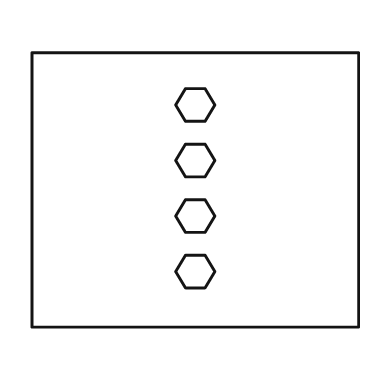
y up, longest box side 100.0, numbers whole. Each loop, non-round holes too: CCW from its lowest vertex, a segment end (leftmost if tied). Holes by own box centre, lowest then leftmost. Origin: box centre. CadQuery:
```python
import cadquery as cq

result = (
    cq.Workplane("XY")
    .moveTo(-50.0, -42.0)
    .lineTo(50.0, -42.0)
    .lineTo(50.0, 42.0)
    .lineTo(-50.0, 42.0)
    .close()
    .moveTo(-3.0, -30.0)
    .lineTo(3.0, -30.0)
    .lineTo(6.0, -25.0)
    .lineTo(3.0, -20.0)
    .lineTo(-3.0, -20.0)
    .lineTo(-6.0, -25.0)
    .close()
    .moveTo(-3.0, -13.0)
    .lineTo(3.0, -13.0)
    .lineTo(6.0, -8.0)
    .lineTo(3.0, -3.0)
    .lineTo(-3.0, -3.0)
    .lineTo(-6.0, -8.0)
    .close()
    .moveTo(-3.0, 4.0)
    .lineTo(3.0, 4.0)
    .lineTo(6.0, 9.0)
    .lineTo(3.0, 14.0)
    .lineTo(-3.0, 14.0)
    .lineTo(-6.0, 9.0)
    .close()
    .moveTo(-3.0, 21.0)
    .lineTo(3.0, 21.0)
    .lineTo(6.0, 26.0)
    .lineTo(3.0, 31.0)
    .lineTo(-3.0, 31.0)
    .lineTo(-6.0, 26.0)
    .close()
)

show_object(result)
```